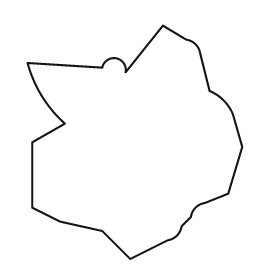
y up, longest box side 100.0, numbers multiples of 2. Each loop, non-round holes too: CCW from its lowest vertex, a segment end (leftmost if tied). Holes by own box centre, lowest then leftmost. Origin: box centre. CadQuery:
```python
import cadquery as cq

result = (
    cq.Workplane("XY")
    .moveTo(-2.0, -50.0)
    .lineTo(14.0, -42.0)
    .threePointArc((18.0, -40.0), (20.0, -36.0))
    .lineTo(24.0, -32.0)
    .threePointArc((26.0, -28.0), (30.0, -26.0))
    .lineTo(40.0, -22.0)
    .lineTo(46.0, -2.0)
    .lineTo(42.0, 12.0)
    .threePointArc((38.0, 18.0), (32.0, 22.0))
    .lineTo(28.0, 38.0)
    .threePointArc((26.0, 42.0), (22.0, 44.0))
    .lineTo(12.0, 50.0)
    .lineTo(-4.0, 30.0)
    .threePointArc((-8.0, 36.0), (-14.0, 32.0))
    .lineTo(-46.0, 34.0)
    .threePointArc((-40.0, 20.0), (-30.0, 8.0))
    .lineTo(-44.0, 0.0)
    .lineTo(-44.0, -28.0)
    .lineTo(-32.0, -34.0)
    .lineTo(-14.0, -38.0)
    .close()
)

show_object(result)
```